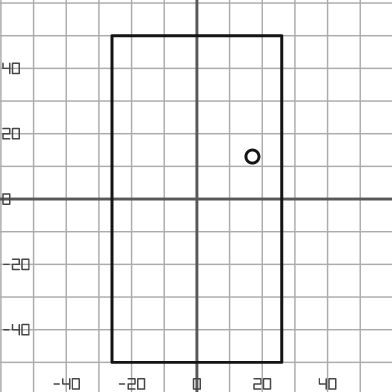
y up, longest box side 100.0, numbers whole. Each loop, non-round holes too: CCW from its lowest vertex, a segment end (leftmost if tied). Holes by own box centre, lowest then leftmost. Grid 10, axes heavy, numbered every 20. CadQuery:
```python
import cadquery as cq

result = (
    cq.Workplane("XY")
    .moveTo(-26.0, -50.0)
    .lineTo(26.0, -50.0)
    .lineTo(26.0, 50.0)
    .lineTo(-26.0, 50.0)
    .close()
    .moveTo(17.0, 13.0)
    .circle(2.0)
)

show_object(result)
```